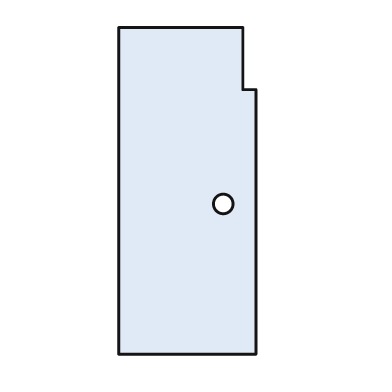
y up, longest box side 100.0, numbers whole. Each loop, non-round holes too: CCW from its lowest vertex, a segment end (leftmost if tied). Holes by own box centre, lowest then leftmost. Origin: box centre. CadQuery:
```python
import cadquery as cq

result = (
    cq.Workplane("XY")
    .moveTo(-21.0, -50.0)
    .lineTo(21.0, -50.0)
    .lineTo(21.0, 31.0)
    .lineTo(17.0, 31.0)
    .lineTo(17.0, 50.0)
    .lineTo(-21.0, 50.0)
    .close()
    .moveTo(11.0, -4.0)
    .circle(3.0)
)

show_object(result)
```